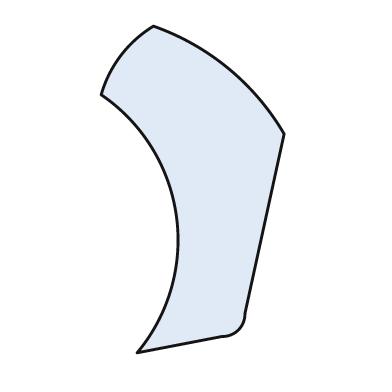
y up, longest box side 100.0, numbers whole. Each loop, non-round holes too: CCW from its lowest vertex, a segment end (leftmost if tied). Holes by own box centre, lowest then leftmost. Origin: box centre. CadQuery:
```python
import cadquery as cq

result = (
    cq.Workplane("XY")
    .moveTo(-17.0, -50.0)
    .lineTo(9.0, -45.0)
    .threePointArc((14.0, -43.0), (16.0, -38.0))
    .lineTo(28.0, 17.0)
    .threePointArc((11.0, 37.0), (-12.0, 50.0))
    .threePointArc((-22.0, 41.0), (-28.0, 29.0))
    .threePointArc((-5.0, -8.0), (-17.0, -50.0))
    .close()
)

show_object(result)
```